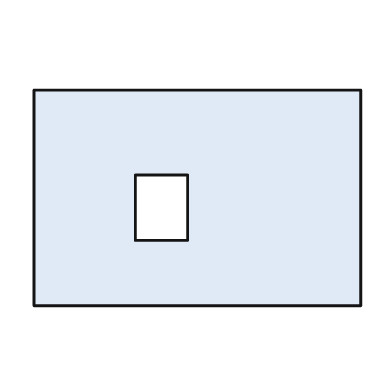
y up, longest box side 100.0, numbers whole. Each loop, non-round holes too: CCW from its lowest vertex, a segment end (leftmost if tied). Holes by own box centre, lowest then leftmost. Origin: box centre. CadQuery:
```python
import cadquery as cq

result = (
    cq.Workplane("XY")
    .moveTo(-50.0, -33.0)
    .lineTo(50.0, -33.0)
    .lineTo(50.0, 33.0)
    .lineTo(-50.0, 33.0)
    .close()
    .moveTo(-19.0, -13.0)
    .lineTo(-3.0, -13.0)
    .lineTo(-3.0, 7.0)
    .lineTo(-19.0, 7.0)
    .close()
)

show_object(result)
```